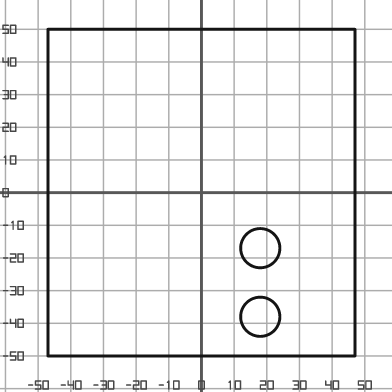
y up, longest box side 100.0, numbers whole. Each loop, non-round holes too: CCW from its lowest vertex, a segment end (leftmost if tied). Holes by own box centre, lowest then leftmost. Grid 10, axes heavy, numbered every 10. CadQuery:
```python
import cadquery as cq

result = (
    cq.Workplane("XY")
    .moveTo(-47.0, -50.0)
    .lineTo(47.0, -50.0)
    .lineTo(47.0, 50.0)
    .lineTo(-47.0, 50.0)
    .close()
    .moveTo(18.0, -38.0)
    .circle(6.0)
    .moveTo(18.0, -17.0)
    .circle(6.0)
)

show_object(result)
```